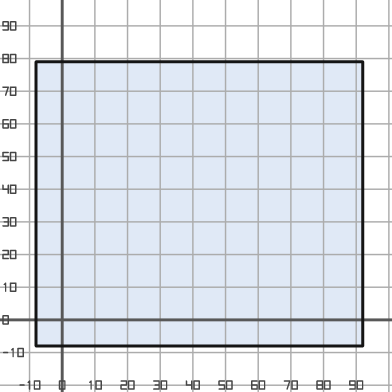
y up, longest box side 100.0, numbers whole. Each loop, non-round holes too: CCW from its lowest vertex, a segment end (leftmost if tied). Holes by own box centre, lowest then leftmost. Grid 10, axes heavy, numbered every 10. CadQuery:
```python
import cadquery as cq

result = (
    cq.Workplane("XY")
    .moveTo(-8.0, -8.0)
    .lineTo(92.0, -8.0)
    .lineTo(92.0, 79.0)
    .lineTo(-8.0, 79.0)
    .close()
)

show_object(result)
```